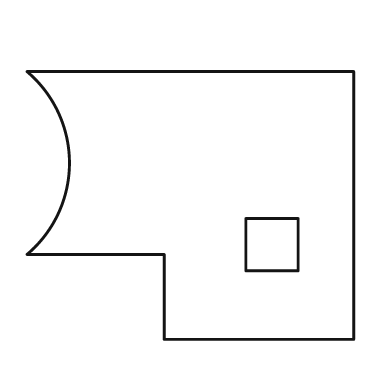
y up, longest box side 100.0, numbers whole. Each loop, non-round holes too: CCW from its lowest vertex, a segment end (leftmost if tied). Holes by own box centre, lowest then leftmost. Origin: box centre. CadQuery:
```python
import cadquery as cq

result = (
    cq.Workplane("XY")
    .moveTo(-8.0, -41.0)
    .lineTo(50.0, -41.0)
    .lineTo(50.0, 41.0)
    .lineTo(-50.0, 41.0)
    .threePointArc((-37.0, 13.0), (-50.0, -15.0))
    .lineTo(-8.0, -15.0)
    .close()
    .moveTo(17.0, -20.0)
    .lineTo(33.0, -20.0)
    .lineTo(33.0, -4.0)
    .lineTo(17.0, -4.0)
    .close()
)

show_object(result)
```